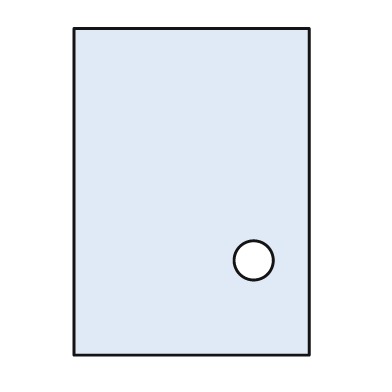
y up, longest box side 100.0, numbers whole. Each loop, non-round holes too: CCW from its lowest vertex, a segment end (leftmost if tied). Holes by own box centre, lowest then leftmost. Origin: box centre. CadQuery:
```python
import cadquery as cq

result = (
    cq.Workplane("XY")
    .moveTo(-36.0, -50.0)
    .lineTo(36.0, -50.0)
    .lineTo(36.0, 50.0)
    .lineTo(-36.0, 50.0)
    .close()
    .moveTo(19.0, -21.0)
    .circle(6.0)
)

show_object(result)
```